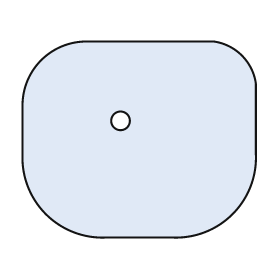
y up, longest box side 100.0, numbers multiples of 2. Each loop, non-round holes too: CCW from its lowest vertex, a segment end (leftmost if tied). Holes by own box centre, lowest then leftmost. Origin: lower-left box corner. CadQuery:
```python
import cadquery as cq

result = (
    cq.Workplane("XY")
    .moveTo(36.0, 0.0)
    .lineTo(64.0, 0.0)
    .threePointArc((90.0, 10.0), (100.0, 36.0))
    .lineTo(100.0, 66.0)
    .threePointArc((94.0, 78.0), (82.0, 84.0))
    .lineTo(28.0, 84.0)
    .threePointArc((8.0, 76.0), (0.0, 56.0))
    .lineTo(0.0, 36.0)
    .threePointArc((10.0, 10.0), (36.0, 0.0))
    .close()
    .moveTo(42.0, 50.0)
    .circle(4.0)
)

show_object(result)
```